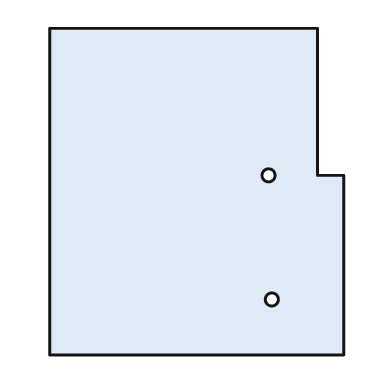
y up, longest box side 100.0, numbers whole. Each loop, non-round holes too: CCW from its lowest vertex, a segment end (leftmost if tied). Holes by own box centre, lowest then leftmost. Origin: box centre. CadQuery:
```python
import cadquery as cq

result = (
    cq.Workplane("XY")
    .moveTo(-45.0, -50.0)
    .lineTo(45.0, -50.0)
    .lineTo(45.0, 5.0)
    .lineTo(37.0, 5.0)
    .lineTo(37.0, 50.0)
    .lineTo(-45.0, 50.0)
    .close()
    .moveTo(23.0, -33.0)
    .circle(2.0)
    .moveTo(22.0, 5.0)
    .circle(2.0)
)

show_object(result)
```